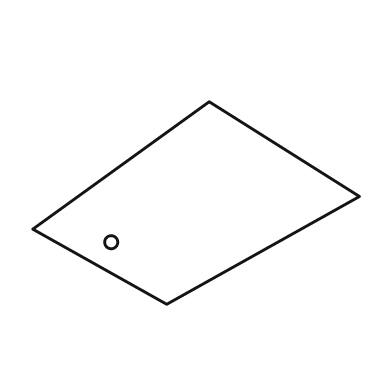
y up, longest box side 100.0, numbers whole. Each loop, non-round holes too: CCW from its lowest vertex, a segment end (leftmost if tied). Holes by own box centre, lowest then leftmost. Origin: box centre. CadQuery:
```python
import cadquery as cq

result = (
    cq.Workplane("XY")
    .moveTo(-9.0, -31.0)
    .lineTo(50.0, 2.0)
    .lineTo(4.0, 31.0)
    .lineTo(-50.0, -8.0)
    .close()
    .moveTo(-26.0, -12.0)
    .circle(2.0)
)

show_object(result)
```